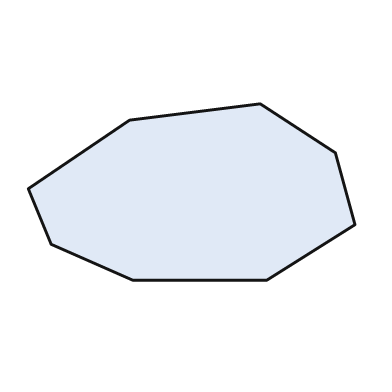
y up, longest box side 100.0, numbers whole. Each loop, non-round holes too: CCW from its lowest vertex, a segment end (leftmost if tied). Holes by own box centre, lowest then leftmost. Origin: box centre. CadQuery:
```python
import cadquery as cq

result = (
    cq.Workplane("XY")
    .moveTo(-18.0, -27.0)
    .lineTo(23.0, -27.0)
    .lineTo(50.0, -10.0)
    .lineTo(44.0, 12.0)
    .lineTo(21.0, 27.0)
    .lineTo(-19.0, 22.0)
    .lineTo(-50.0, 1.0)
    .lineTo(-43.0, -16.0)
    .close()
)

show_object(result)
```